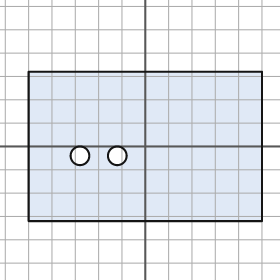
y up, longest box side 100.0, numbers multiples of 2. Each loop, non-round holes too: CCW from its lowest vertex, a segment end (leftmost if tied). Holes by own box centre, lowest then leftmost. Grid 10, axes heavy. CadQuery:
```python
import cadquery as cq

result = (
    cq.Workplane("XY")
    .moveTo(-50.0, -32.0)
    .lineTo(50.0, -32.0)
    .lineTo(50.0, 32.0)
    .lineTo(-50.0, 32.0)
    .close()
    .moveTo(-28.0, -4.0)
    .circle(4.0)
    .moveTo(-12.0, -4.0)
    .circle(4.0)
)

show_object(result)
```